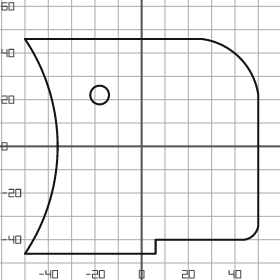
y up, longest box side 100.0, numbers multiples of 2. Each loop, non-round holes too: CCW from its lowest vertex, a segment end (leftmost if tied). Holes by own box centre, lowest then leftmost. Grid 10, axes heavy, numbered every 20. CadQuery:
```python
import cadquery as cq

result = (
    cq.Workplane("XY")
    .moveTo(-50.0, -46.0)
    .lineTo(6.0, -46.0)
    .lineTo(6.0, -40.0)
    .lineTo(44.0, -40.0)
    .threePointArc((48.0, -38.0), (50.0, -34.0))
    .lineTo(50.0, 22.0)
    .threePointArc((42.0, 38.0), (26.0, 46.0))
    .lineTo(-50.0, 46.0)
    .threePointArc((-36.0, 0.0), (-50.0, -46.0))
    .close()
    .moveTo(-18.0, 22.0)
    .circle(4.0)
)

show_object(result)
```